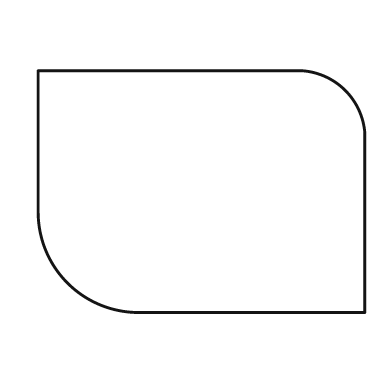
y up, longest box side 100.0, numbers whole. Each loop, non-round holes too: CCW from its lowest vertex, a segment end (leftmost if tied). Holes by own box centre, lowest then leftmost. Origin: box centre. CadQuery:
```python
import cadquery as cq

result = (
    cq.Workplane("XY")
    .moveTo(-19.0, -37.0)
    .lineTo(50.0, -37.0)
    .lineTo(50.0, 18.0)
    .threePointArc((44.0, 31.0), (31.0, 37.0))
    .lineTo(-50.0, 37.0)
    .lineTo(-50.0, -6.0)
    .threePointArc((-41.0, -28.0), (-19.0, -37.0))
    .close()
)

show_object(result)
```